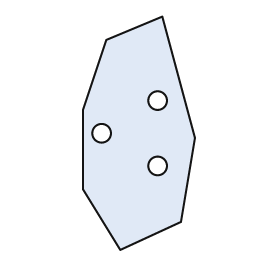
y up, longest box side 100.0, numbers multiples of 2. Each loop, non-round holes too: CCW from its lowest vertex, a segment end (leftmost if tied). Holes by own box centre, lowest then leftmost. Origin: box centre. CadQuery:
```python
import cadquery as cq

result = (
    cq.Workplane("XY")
    .moveTo(-8.0, -50.0)
    .lineTo(18.0, -38.0)
    .lineTo(24.0, -2.0)
    .lineTo(10.0, 50.0)
    .lineTo(-14.0, 40.0)
    .lineTo(-24.0, 10.0)
    .lineTo(-24.0, -24.0)
    .close()
    .moveTo(8.0, -14.0)
    .circle(4.0)
    .moveTo(-16.0, 0.0)
    .circle(4.0)
    .moveTo(8.0, 14.0)
    .circle(4.0)
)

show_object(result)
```